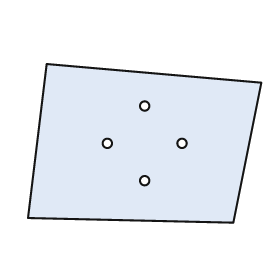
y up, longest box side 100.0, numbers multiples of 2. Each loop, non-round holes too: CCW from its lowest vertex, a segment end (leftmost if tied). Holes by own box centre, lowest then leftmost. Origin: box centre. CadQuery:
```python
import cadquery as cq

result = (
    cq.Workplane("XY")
    .moveTo(38.0, -34.0)
    .lineTo(50.0, 26.0)
    .lineTo(-42.0, 34.0)
    .lineTo(-50.0, -32.0)
    .close()
    .moveTo(0.0, -16.0)
    .circle(2.0)
    .moveTo(-16.0, 0.0)
    .circle(2.0)
    .moveTo(16.0, 0.0)
    .circle(2.0)
    .moveTo(0.0, 16.0)
    .circle(2.0)
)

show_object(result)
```